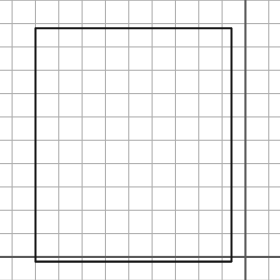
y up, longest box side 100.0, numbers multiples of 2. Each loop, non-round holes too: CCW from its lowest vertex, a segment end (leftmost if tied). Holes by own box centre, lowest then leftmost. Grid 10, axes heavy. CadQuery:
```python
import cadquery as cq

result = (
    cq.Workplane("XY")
    .moveTo(-90.0, -2.0)
    .lineTo(-6.0, -2.0)
    .lineTo(-6.0, 98.0)
    .lineTo(-90.0, 98.0)
    .close()
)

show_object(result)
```